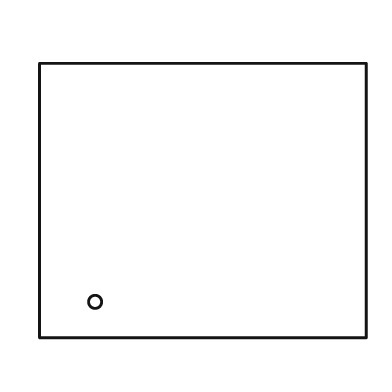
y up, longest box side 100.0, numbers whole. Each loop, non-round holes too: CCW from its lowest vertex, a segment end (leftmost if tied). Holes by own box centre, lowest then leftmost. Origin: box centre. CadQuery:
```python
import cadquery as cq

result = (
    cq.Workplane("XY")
    .moveTo(-50.0, -42.0)
    .lineTo(50.0, -42.0)
    .lineTo(50.0, 42.0)
    .lineTo(-50.0, 42.0)
    .close()
    .moveTo(-33.0, -31.0)
    .circle(2.0)
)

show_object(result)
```